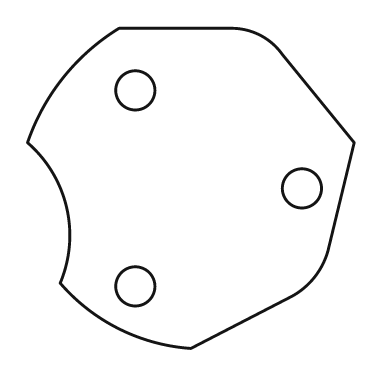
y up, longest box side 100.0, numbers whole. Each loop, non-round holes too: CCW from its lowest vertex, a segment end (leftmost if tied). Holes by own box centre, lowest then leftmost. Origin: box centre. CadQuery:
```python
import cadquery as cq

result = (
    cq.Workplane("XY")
    .moveTo(0.0, -49.0)
    .lineTo(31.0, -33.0)
    .threePointArc((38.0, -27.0), (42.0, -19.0))
    .lineTo(50.0, 14.0)
    .lineTo(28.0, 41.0)
    .threePointArc((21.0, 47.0), (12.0, 49.0))
    .lineTo(-22.0, 49.0)
    .threePointArc((-39.0, 34.0), (-50.0, 14.0))
    .threePointArc((-38.0, -6.0), (-40.0, -29.0))
    .threePointArc((-22.0, -43.0), (0.0, -49.0))
    .close()
    .moveTo(-17.0, -30.0)
    .circle(6.0)
    .moveTo(34.0, 0.0)
    .circle(6.0)
    .moveTo(-17.0, 30.0)
    .circle(6.0)
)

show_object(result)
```